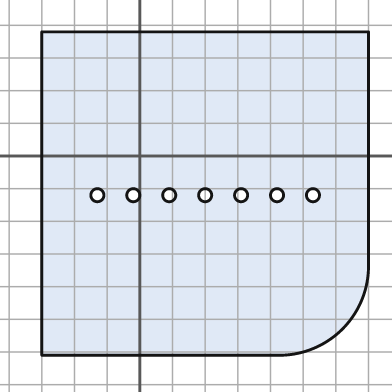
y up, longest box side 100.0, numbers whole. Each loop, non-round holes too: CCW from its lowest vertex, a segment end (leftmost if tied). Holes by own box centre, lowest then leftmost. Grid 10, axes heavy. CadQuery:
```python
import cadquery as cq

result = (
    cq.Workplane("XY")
    .moveTo(-30.0, -61.0)
    .lineTo(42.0, -61.0)
    .threePointArc((62.0, -53.0), (70.0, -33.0))
    .lineTo(70.0, 38.0)
    .lineTo(-30.0, 38.0)
    .close()
    .moveTo(-13.0, -12.0)
    .circle(2.0)
    .moveTo(-2.0, -12.0)
    .circle(2.0)
    .moveTo(9.0, -12.0)
    .circle(2.0)
    .moveTo(20.0, -12.0)
    .circle(2.0)
    .moveTo(31.0, -12.0)
    .circle(2.0)
    .moveTo(42.0, -12.0)
    .circle(2.0)
    .moveTo(53.0, -12.0)
    .circle(2.0)
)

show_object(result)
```